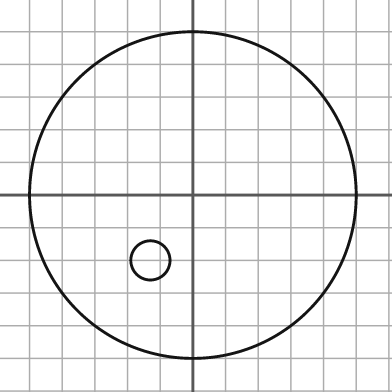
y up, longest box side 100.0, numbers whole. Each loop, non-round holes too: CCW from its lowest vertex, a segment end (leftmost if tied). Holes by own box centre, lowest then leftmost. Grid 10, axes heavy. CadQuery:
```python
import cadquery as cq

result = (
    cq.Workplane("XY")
    .moveTo(0.0, 0.0)
    .circle(50.0)
    .moveTo(-13.0, -20.0)
    .circle(6.0)
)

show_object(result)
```